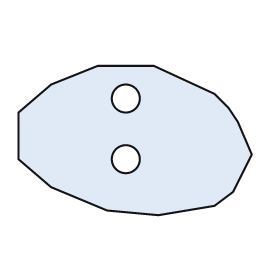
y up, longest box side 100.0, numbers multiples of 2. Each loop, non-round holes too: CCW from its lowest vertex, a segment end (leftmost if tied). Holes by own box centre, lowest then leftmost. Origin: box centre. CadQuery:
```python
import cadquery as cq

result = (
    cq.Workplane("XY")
    .moveTo(10.0, -32.0)
    .lineTo(34.0, -28.0)
    .lineTo(42.0, -22.0)
    .lineTo(50.0, -6.0)
    .lineTo(44.0, 8.0)
    .lineTo(40.0, 14.0)
    .lineTo(34.0, 20.0)
    .lineTo(8.0, 32.0)
    .lineTo(-16.0, 32.0)
    .lineTo(-36.0, 24.0)
    .lineTo(-50.0, 12.0)
    .lineTo(-50.0, -8.0)
    .lineTo(-36.0, -20.0)
    .lineTo(-12.0, -30.0)
    .close()
    .moveTo(-4.0, -8.0)
    .circle(6.0)
    .moveTo(-4.0, 18.0)
    .circle(6.0)
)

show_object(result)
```